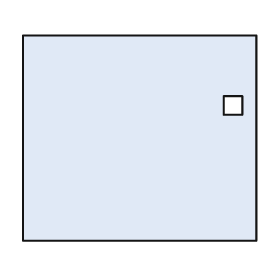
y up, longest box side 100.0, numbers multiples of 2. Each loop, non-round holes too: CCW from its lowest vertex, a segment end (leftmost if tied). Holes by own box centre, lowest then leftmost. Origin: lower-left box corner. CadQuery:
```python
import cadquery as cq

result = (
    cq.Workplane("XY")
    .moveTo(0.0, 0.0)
    .lineTo(100.0, 0.0)
    .lineTo(100.0, 88.0)
    .lineTo(0.0, 88.0)
    .close()
    .moveTo(86.0, 54.0)
    .lineTo(94.0, 54.0)
    .lineTo(94.0, 62.0)
    .lineTo(86.0, 62.0)
    .close()
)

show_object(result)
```